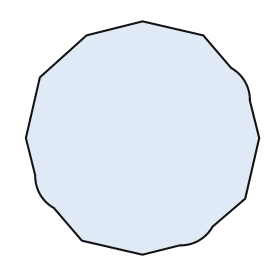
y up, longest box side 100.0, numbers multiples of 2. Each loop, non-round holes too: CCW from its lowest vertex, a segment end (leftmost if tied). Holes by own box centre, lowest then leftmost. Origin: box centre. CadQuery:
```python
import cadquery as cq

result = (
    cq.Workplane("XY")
    .moveTo(0.0, -50.0)
    .lineTo(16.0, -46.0)
    .threePointArc((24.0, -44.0), (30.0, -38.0))
    .lineTo(44.0, -26.0)
    .lineTo(50.0, 0.0)
    .lineTo(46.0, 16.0)
    .threePointArc((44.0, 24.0), (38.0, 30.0))
    .lineTo(26.0, 44.0)
    .lineTo(0.0, 50.0)
    .lineTo(-24.0, 44.0)
    .lineTo(-44.0, 26.0)
    .lineTo(-50.0, 0.0)
    .lineTo(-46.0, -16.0)
    .threePointArc((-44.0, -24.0), (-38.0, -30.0))
    .lineTo(-26.0, -44.0)
    .close()
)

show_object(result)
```